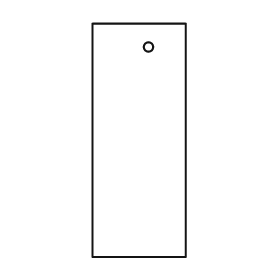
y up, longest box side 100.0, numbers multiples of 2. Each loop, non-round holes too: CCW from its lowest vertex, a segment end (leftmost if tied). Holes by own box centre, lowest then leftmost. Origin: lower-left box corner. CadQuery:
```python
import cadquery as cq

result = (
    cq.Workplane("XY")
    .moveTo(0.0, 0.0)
    .lineTo(40.0, 0.0)
    .lineTo(40.0, 100.0)
    .lineTo(0.0, 100.0)
    .close()
    .moveTo(24.0, 90.0)
    .circle(2.0)
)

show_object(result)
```